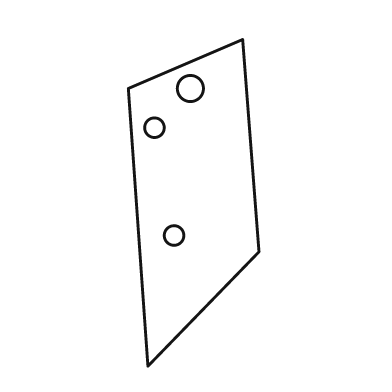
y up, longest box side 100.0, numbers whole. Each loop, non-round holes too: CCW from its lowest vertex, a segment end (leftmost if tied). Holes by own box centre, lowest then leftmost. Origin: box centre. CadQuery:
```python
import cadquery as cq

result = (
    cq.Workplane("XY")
    .moveTo(-14.0, -50.0)
    .lineTo(20.0, -15.0)
    .lineTo(15.0, 50.0)
    .lineTo(-20.0, 35.0)
    .close()
    .moveTo(-6.0, -10.0)
    .circle(3.0)
    .moveTo(-12.0, 23.0)
    .circle(3.0)
    .moveTo(-1.0, 35.0)
    .circle(4.0)
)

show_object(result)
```